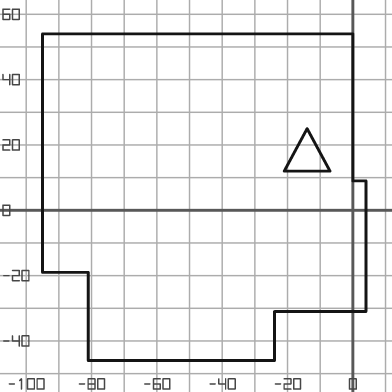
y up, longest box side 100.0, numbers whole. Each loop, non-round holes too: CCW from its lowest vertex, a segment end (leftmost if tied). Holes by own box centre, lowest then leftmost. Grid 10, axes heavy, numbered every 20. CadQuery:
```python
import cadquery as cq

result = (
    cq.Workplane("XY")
    .moveTo(-81.0, -46.0)
    .lineTo(-24.0, -46.0)
    .lineTo(-24.0, -31.0)
    .lineTo(4.0, -31.0)
    .lineTo(4.0, 9.0)
    .lineTo(0.0, 9.0)
    .lineTo(0.0, 54.0)
    .lineTo(-95.0, 54.0)
    .lineTo(-95.0, -19.0)
    .lineTo(-81.0, -19.0)
    .close()
    .moveTo(-21.0, 12.0)
    .lineTo(-7.0, 12.0)
    .lineTo(-14.0, 25.0)
    .close()
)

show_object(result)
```